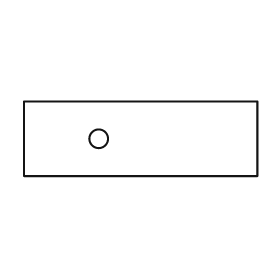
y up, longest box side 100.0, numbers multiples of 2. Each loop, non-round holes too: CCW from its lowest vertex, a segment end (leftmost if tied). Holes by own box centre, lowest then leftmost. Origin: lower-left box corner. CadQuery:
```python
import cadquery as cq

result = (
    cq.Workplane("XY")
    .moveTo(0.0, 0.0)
    .lineTo(100.0, 0.0)
    .lineTo(100.0, 32.0)
    .lineTo(0.0, 32.0)
    .close()
    .moveTo(32.0, 16.0)
    .circle(4.0)
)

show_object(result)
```